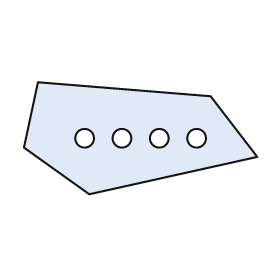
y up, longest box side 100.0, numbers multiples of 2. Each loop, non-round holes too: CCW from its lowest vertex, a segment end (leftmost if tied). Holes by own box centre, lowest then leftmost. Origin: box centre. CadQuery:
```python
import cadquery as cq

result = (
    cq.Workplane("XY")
    .moveTo(-22.0, -24.0)
    .lineTo(50.0, -8.0)
    .lineTo(30.0, 18.0)
    .lineTo(-44.0, 24.0)
    .lineTo(-50.0, -4.0)
    .close()
    .moveTo(-24.0, 0.0)
    .circle(4.0)
    .moveTo(-8.0, 0.0)
    .circle(4.0)
    .moveTo(8.0, 0.0)
    .circle(4.0)
    .moveTo(24.0, 0.0)
    .circle(4.0)
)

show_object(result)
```